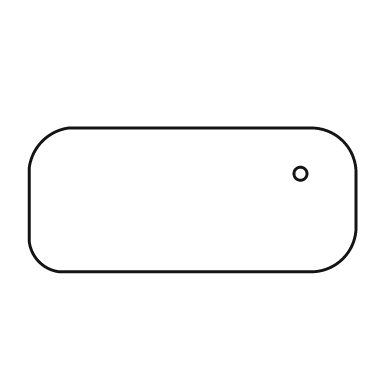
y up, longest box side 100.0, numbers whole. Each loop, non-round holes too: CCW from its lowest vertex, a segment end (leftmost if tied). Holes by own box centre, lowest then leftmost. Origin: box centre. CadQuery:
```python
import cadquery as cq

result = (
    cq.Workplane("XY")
    .moveTo(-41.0, -22.0)
    .lineTo(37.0, -22.0)
    .threePointArc((46.0, -18.0), (50.0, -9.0))
    .lineTo(50.0, 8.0)
    .threePointArc((46.0, 18.0), (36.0, 22.0))
    .lineTo(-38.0, 22.0)
    .threePointArc((-46.0, 18.0), (-50.0, 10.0))
    .lineTo(-50.0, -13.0)
    .threePointArc((-47.0, -19.0), (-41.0, -22.0))
    .close()
    .moveTo(33.0, 8.0)
    .circle(2.0)
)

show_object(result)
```